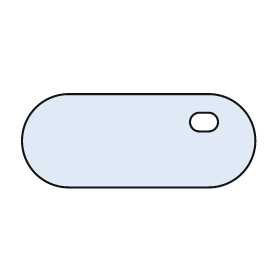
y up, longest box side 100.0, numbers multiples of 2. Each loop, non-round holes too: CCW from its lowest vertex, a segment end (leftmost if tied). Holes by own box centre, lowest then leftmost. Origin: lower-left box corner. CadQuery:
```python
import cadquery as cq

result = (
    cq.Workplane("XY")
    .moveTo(20.0, 0.0)
    .lineTo(80.0, 0.0)
    .threePointArc((100.0, 20.0), (80.0, 40.0))
    .lineTo(20.0, 40.0)
    .threePointArc((0.0, 20.0), (20.0, 0.0))
    .close()
    .moveTo(76.0, 24.0)
    .lineTo(80.0, 24.0)
    .threePointArc((84.0, 28.0), (80.0, 32.0))
    .lineTo(76.0, 32.0)
    .threePointArc((72.0, 28.0), (76.0, 24.0))
    .close()
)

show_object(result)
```